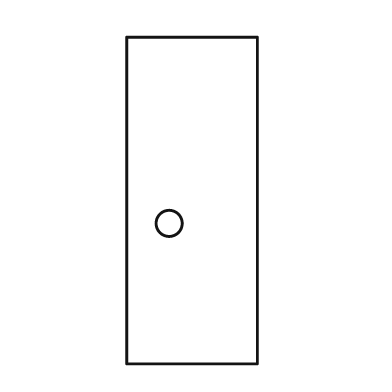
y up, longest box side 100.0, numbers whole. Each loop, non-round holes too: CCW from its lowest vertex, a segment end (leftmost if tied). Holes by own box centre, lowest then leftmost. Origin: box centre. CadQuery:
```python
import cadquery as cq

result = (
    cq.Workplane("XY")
    .moveTo(-20.0, -50.0)
    .lineTo(20.0, -50.0)
    .lineTo(20.0, 50.0)
    .lineTo(-20.0, 50.0)
    .close()
    .moveTo(-7.0, -7.0)
    .circle(4.0)
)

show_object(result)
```